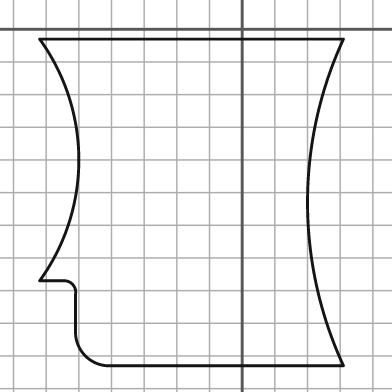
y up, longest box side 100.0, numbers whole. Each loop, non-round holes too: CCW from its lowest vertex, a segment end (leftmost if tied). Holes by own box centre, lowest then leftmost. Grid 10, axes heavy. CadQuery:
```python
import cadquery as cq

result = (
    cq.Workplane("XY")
    .moveTo(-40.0, -103.0)
    .lineTo(31.0, -103.0)
    .threePointArc((20.0, -53.0), (31.0, -3.0))
    .lineTo(-62.0, -3.0)
    .threePointArc((-50.0, -40.0), (-62.0, -77.0))
    .lineTo(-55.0, -77.0)
    .threePointArc((-52.0, -78.0), (-51.0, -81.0))
    .lineTo(-51.0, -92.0)
    .threePointArc((-48.0, -100.0), (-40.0, -103.0))
    .close()
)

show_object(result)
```